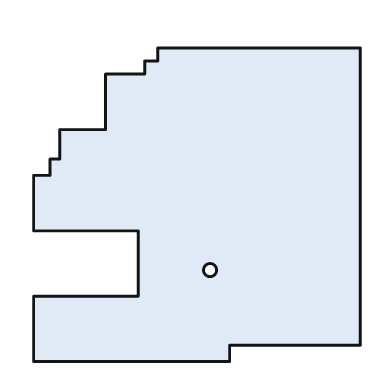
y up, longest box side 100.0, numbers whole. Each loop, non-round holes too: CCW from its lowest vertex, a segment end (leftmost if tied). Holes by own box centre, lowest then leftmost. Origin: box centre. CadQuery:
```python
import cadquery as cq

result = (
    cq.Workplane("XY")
    .moveTo(-50.0, -48.0)
    .lineTo(10.0, -48.0)
    .lineTo(10.0, -43.0)
    .lineTo(50.0, -43.0)
    .lineTo(50.0, 48.0)
    .lineTo(-12.0, 48.0)
    .lineTo(-12.0, 44.0)
    .lineTo(-16.0, 44.0)
    .lineTo(-16.0, 40.0)
    .lineTo(-28.0, 40.0)
    .lineTo(-28.0, 23.0)
    .lineTo(-42.0, 23.0)
    .lineTo(-42.0, 14.0)
    .lineTo(-45.0, 14.0)
    .lineTo(-45.0, 9.0)
    .lineTo(-50.0, 9.0)
    .lineTo(-50.0, -8.0)
    .lineTo(-18.0, -8.0)
    .lineTo(-18.0, -28.0)
    .lineTo(-50.0, -28.0)
    .close()
    .moveTo(4.0, -20.0)
    .circle(2.0)
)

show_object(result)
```